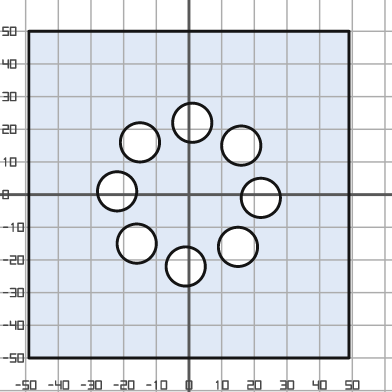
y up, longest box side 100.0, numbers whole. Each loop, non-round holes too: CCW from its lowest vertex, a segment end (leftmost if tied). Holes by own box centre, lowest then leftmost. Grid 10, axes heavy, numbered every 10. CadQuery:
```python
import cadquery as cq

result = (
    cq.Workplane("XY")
    .moveTo(-49.0, -50.0)
    .lineTo(49.0, -50.0)
    .lineTo(49.0, 50.0)
    .lineTo(-49.0, 50.0)
    .close()
    .moveTo(-1.0, -22.0)
    .circle(6.0)
    .moveTo(15.0, -16.0)
    .circle(6.0)
    .moveTo(-16.0, -15.0)
    .circle(6.0)
    .moveTo(22.0, -1.0)
    .circle(6.0)
    .moveTo(-22.0, 1.0)
    .circle(6.0)
    .moveTo(16.0, 15.0)
    .circle(6.0)
    .moveTo(-15.0, 16.0)
    .circle(6.0)
    .moveTo(1.0, 22.0)
    .circle(6.0)
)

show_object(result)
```